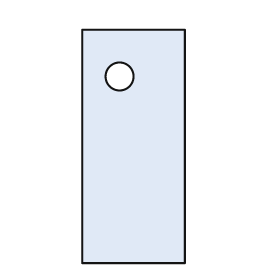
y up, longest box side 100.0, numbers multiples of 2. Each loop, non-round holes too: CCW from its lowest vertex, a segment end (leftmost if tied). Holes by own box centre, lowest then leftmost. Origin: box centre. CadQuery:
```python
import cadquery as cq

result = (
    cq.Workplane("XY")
    .moveTo(-22.0, -50.0)
    .lineTo(22.0, -50.0)
    .lineTo(22.0, 50.0)
    .lineTo(-22.0, 50.0)
    .close()
    .moveTo(-6.0, 30.0)
    .circle(6.0)
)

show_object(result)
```